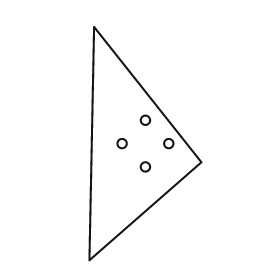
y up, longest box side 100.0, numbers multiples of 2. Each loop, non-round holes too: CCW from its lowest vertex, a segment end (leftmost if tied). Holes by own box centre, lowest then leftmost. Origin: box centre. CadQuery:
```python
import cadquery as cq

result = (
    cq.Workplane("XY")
    .moveTo(-24.0, -50.0)
    .lineTo(24.0, -8.0)
    .lineTo(-22.0, 50.0)
    .close()
    .moveTo(0.0, -10.0)
    .circle(2.0)
    .moveTo(-10.0, 0.0)
    .circle(2.0)
    .moveTo(10.0, 0.0)
    .circle(2.0)
    .moveTo(0.0, 10.0)
    .circle(2.0)
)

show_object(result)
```